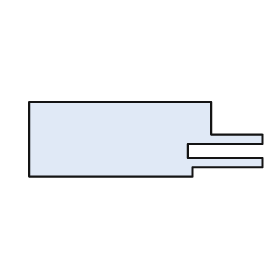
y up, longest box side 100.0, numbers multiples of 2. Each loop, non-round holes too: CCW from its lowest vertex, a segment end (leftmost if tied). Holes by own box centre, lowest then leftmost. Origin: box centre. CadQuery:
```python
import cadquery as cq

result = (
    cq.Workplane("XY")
    .moveTo(-50.0, -16.0)
    .lineTo(20.0, -16.0)
    .lineTo(20.0, -12.0)
    .lineTo(50.0, -12.0)
    .lineTo(50.0, -8.0)
    .lineTo(18.0, -8.0)
    .lineTo(18.0, -2.0)
    .lineTo(50.0, -2.0)
    .lineTo(50.0, 2.0)
    .lineTo(28.0, 2.0)
    .lineTo(28.0, 16.0)
    .lineTo(-50.0, 16.0)
    .close()
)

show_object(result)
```